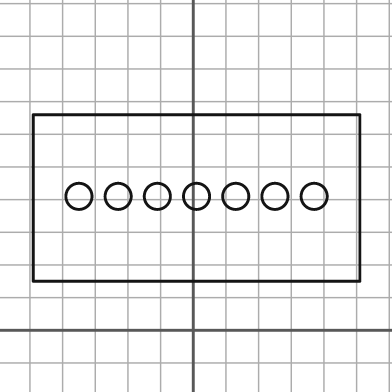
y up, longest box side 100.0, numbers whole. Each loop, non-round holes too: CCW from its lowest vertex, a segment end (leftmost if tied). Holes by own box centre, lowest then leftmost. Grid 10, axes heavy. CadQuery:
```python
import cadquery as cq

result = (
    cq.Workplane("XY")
    .moveTo(-49.0, 15.0)
    .lineTo(51.0, 15.0)
    .lineTo(51.0, 66.0)
    .lineTo(-49.0, 66.0)
    .close()
    .moveTo(-35.0, 41.0)
    .circle(4.0)
    .moveTo(-23.0, 41.0)
    .circle(4.0)
    .moveTo(-11.0, 41.0)
    .circle(4.0)
    .moveTo(1.0, 41.0)
    .circle(4.0)
    .moveTo(13.0, 41.0)
    .circle(4.0)
    .moveTo(25.0, 41.0)
    .circle(4.0)
    .moveTo(37.0, 41.0)
    .circle(4.0)
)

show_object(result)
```